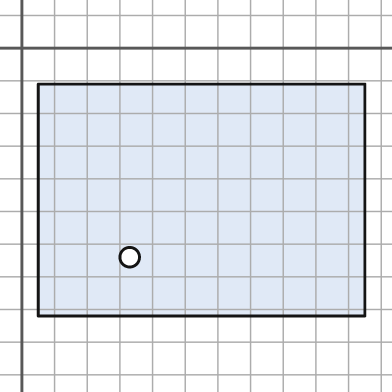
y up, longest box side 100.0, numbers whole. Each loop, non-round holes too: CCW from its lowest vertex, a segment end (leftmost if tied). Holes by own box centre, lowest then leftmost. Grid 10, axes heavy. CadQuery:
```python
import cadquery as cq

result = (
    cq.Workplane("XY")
    .moveTo(5.0, -82.0)
    .lineTo(105.0, -82.0)
    .lineTo(105.0, -11.0)
    .lineTo(5.0, -11.0)
    .close()
    .moveTo(33.0, -64.0)
    .circle(3.0)
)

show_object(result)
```